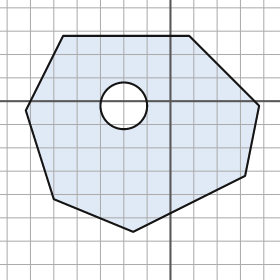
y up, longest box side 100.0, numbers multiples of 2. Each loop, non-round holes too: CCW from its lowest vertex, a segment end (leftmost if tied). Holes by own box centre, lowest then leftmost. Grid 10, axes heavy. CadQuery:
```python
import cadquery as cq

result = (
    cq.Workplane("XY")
    .moveTo(-16.0, -56.0)
    .lineTo(32.0, -32.0)
    .lineTo(38.0, -2.0)
    .lineTo(8.0, 28.0)
    .lineTo(-46.0, 28.0)
    .lineTo(-62.0, -4.0)
    .lineTo(-50.0, -42.0)
    .close()
    .moveTo(-20.0, -2.0)
    .circle(10.0)
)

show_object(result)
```